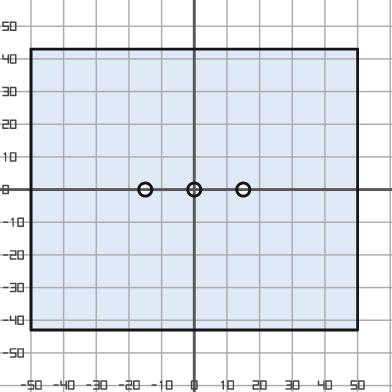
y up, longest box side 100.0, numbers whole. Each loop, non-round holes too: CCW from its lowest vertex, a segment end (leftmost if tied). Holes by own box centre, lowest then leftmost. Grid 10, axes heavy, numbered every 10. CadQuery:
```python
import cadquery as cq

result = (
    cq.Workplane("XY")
    .moveTo(-50.0, -43.0)
    .lineTo(50.0, -43.0)
    .lineTo(50.0, 43.0)
    .lineTo(-50.0, 43.0)
    .close()
    .moveTo(-15.0, 0.0)
    .circle(2.0)
    .moveTo(0.0, 0.0)
    .circle(2.0)
    .moveTo(15.0, 0.0)
    .circle(2.0)
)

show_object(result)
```